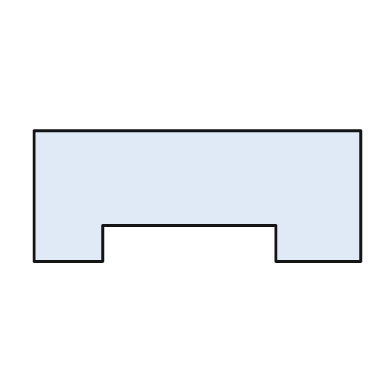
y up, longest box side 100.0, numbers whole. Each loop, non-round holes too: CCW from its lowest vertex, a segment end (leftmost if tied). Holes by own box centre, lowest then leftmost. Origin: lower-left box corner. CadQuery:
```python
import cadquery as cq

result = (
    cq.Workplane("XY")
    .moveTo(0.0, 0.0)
    .lineTo(21.0, 0.0)
    .lineTo(21.0, 11.0)
    .lineTo(74.0, 11.0)
    .lineTo(74.0, 0.0)
    .lineTo(100.0, 0.0)
    .lineTo(100.0, 40.0)
    .lineTo(0.0, 40.0)
    .close()
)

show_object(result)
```